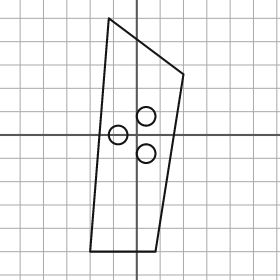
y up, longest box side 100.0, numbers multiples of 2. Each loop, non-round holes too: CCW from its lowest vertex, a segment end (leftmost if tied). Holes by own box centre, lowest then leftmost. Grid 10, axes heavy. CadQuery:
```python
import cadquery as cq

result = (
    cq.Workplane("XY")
    .moveTo(-20.0, -50.0)
    .lineTo(8.0, -50.0)
    .lineTo(20.0, 26.0)
    .lineTo(-12.0, 50.0)
    .close()
    .moveTo(4.0, -8.0)
    .circle(4.0)
    .moveTo(-8.0, 0.0)
    .circle(4.0)
    .moveTo(4.0, 8.0)
    .circle(4.0)
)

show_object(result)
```